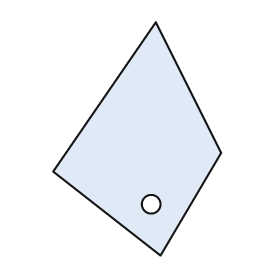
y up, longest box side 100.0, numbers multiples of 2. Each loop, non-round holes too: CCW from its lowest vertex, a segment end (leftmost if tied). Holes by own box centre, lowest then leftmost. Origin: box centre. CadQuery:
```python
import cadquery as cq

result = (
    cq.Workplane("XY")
    .moveTo(10.0, -50.0)
    .lineTo(36.0, -6.0)
    .lineTo(8.0, 50.0)
    .lineTo(-36.0, -14.0)
    .close()
    .moveTo(6.0, -28.0)
    .circle(4.0)
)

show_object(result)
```